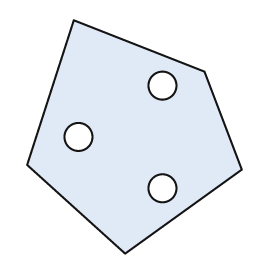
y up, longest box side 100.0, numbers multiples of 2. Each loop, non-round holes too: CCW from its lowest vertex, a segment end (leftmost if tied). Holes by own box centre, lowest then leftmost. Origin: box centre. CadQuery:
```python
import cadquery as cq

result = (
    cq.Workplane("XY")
    .moveTo(-4.0, -50.0)
    .lineTo(46.0, -14.0)
    .lineTo(30.0, 28.0)
    .lineTo(-26.0, 50.0)
    .lineTo(-46.0, -12.0)
    .close()
    .moveTo(12.0, -22.0)
    .circle(6.0)
    .moveTo(-24.0, 0.0)
    .circle(6.0)
    .moveTo(12.0, 22.0)
    .circle(6.0)
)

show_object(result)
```